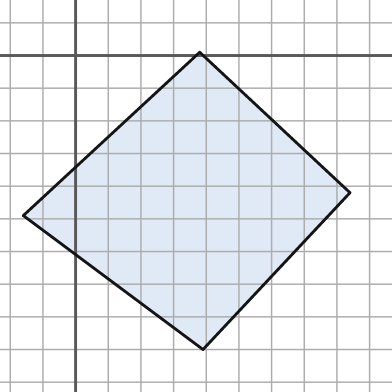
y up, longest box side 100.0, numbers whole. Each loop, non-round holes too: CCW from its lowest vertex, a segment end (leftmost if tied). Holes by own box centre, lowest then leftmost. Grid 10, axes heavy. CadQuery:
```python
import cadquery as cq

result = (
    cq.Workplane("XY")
    .moveTo(39.0, -90.0)
    .lineTo(84.0, -42.0)
    .lineTo(38.0, 1.0)
    .lineTo(-16.0, -49.0)
    .close()
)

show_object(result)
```